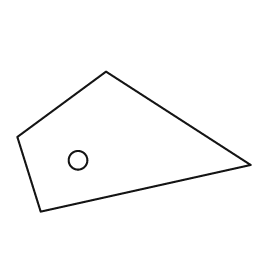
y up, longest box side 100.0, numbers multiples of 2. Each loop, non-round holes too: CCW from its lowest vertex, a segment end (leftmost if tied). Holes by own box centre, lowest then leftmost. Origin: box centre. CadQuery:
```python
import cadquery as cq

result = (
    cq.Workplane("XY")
    .moveTo(-40.0, -30.0)
    .lineTo(50.0, -10.0)
    .lineTo(-12.0, 30.0)
    .lineTo(-50.0, 2.0)
    .close()
    .moveTo(-24.0, -8.0)
    .circle(4.0)
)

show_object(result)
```